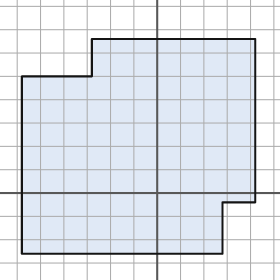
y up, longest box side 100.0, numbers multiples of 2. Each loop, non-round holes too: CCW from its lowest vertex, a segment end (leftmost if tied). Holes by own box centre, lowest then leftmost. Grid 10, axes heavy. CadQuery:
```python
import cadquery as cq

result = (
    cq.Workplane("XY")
    .moveTo(-58.0, -26.0)
    .lineTo(28.0, -26.0)
    .lineTo(28.0, -4.0)
    .lineTo(42.0, -4.0)
    .lineTo(42.0, 66.0)
    .lineTo(-28.0, 66.0)
    .lineTo(-28.0, 50.0)
    .lineTo(-58.0, 50.0)
    .close()
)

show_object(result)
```